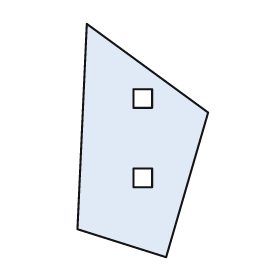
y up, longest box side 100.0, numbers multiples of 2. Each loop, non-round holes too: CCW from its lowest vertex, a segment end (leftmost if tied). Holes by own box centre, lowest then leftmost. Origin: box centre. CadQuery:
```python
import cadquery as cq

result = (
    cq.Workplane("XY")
    .moveTo(10.0, -50.0)
    .lineTo(28.0, 12.0)
    .lineTo(-24.0, 50.0)
    .lineTo(-28.0, -38.0)
    .close()
    .moveTo(-4.0, -20.0)
    .lineTo(4.0, -20.0)
    .lineTo(4.0, -12.0)
    .lineTo(-4.0, -12.0)
    .close()
    .moveTo(-4.0, 14.0)
    .lineTo(4.0, 14.0)
    .lineTo(4.0, 22.0)
    .lineTo(-4.0, 22.0)
    .close()
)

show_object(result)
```